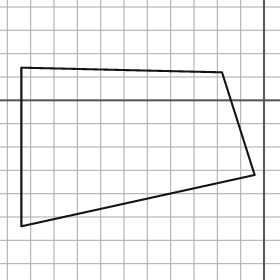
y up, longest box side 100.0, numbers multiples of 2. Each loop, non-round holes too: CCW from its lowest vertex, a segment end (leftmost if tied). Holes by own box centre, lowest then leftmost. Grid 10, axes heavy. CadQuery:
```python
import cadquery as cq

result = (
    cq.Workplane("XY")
    .moveTo(-104.0, -54.0)
    .lineTo(-4.0, -32.0)
    .lineTo(-18.0, 12.0)
    .lineTo(-104.0, 14.0)
    .close()
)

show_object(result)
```